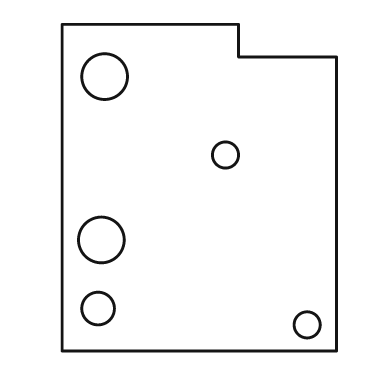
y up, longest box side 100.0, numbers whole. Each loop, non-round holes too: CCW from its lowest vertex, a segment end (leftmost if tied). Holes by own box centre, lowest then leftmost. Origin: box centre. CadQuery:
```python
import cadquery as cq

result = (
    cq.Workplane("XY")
    .moveTo(-42.0, -50.0)
    .lineTo(42.0, -50.0)
    .lineTo(42.0, 40.0)
    .lineTo(12.0, 40.0)
    .lineTo(12.0, 50.0)
    .lineTo(-42.0, 50.0)
    .close()
    .moveTo(33.0, -42.0)
    .circle(4.0)
    .moveTo(-31.0, -37.0)
    .circle(5.0)
    .moveTo(-30.0, -16.0)
    .circle(7.0)
    .moveTo(8.0, 10.0)
    .circle(4.0)
    .moveTo(-29.0, 34.0)
    .circle(7.0)
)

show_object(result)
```